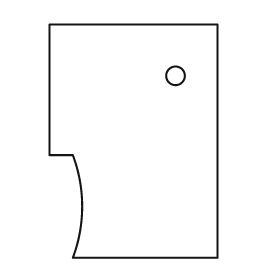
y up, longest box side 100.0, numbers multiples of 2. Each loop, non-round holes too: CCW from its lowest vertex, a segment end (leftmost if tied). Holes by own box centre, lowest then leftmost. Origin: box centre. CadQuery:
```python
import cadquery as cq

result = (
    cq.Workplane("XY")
    .moveTo(-26.0, -50.0)
    .lineTo(36.0, -50.0)
    .lineTo(36.0, 50.0)
    .lineTo(-36.0, 50.0)
    .lineTo(-36.0, -6.0)
    .lineTo(-26.0, -6.0)
    .threePointArc((-22.0, -28.0), (-26.0, -50.0))
    .close()
    .moveTo(18.0, 28.0)
    .circle(4.0)
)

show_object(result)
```